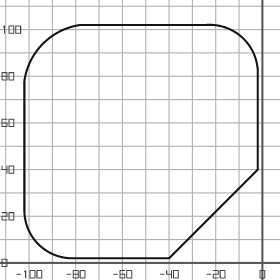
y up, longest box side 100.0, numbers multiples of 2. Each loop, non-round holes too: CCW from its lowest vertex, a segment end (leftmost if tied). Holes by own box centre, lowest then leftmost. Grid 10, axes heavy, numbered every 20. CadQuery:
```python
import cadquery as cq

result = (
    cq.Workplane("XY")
    .moveTo(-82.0, 2.0)
    .lineTo(-40.0, 2.0)
    .lineTo(-2.0, 40.0)
    .lineTo(-2.0, 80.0)
    .threePointArc((-8.0, 96.0), (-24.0, 102.0))
    .lineTo(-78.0, 102.0)
    .threePointArc((-94.0, 94.0), (-102.0, 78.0))
    .lineTo(-102.0, 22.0)
    .threePointArc((-96.0, 8.0), (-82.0, 2.0))
    .close()
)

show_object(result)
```